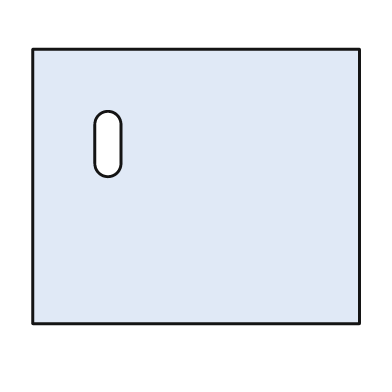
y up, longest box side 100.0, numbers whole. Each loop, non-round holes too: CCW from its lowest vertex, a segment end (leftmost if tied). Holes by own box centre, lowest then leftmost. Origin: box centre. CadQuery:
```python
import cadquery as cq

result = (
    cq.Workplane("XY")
    .moveTo(-50.0, -42.0)
    .lineTo(50.0, -42.0)
    .lineTo(50.0, 42.0)
    .lineTo(-50.0, 42.0)
    .close()
    .moveTo(-31.0, 7.0)
    .threePointArc((-27.0, 3.0), (-23.0, 7.0))
    .lineTo(-23.0, 19.0)
    .threePointArc((-27.0, 23.0), (-31.0, 19.0))
    .close()
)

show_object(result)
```